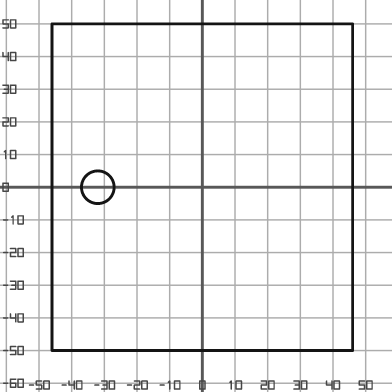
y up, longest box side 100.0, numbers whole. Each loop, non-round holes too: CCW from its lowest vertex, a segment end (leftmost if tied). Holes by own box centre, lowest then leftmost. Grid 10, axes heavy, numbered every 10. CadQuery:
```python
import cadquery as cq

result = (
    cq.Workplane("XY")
    .moveTo(-46.0, -50.0)
    .lineTo(46.0, -50.0)
    .lineTo(46.0, 50.0)
    .lineTo(-46.0, 50.0)
    .close()
    .moveTo(-32.0, 0.0)
    .circle(5.0)
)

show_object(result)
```